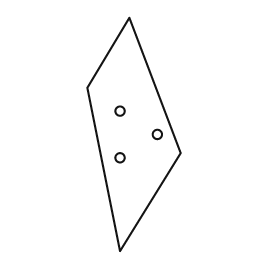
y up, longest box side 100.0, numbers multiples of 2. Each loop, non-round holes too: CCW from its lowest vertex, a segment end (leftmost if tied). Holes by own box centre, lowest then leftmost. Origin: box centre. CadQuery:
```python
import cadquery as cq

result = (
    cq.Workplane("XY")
    .moveTo(-6.0, -50.0)
    .lineTo(20.0, -8.0)
    .lineTo(-2.0, 50.0)
    .lineTo(-20.0, 20.0)
    .close()
    .moveTo(-6.0, -10.0)
    .circle(2.0)
    .moveTo(10.0, 0.0)
    .circle(2.0)
    .moveTo(-6.0, 10.0)
    .circle(2.0)
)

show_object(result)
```